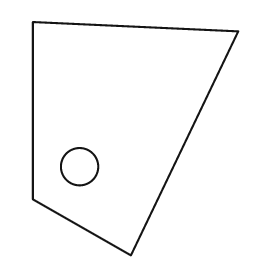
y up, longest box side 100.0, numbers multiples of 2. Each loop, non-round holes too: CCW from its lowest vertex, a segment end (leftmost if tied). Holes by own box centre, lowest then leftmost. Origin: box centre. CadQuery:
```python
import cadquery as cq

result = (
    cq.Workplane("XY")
    .moveTo(-2.0, -50.0)
    .lineTo(44.0, 46.0)
    .lineTo(-44.0, 50.0)
    .lineTo(-44.0, -26.0)
    .close()
    .moveTo(-24.0, -12.0)
    .circle(8.0)
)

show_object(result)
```